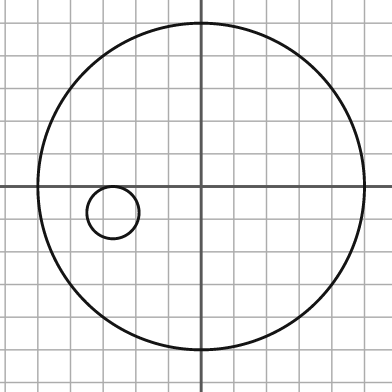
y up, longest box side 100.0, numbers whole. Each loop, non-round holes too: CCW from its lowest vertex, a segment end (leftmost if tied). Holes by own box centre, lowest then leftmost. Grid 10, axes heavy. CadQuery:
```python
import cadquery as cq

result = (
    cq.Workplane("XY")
    .moveTo(0.0, 0.0)
    .circle(50.0)
    .moveTo(-27.0, -8.0)
    .circle(8.0)
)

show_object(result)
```